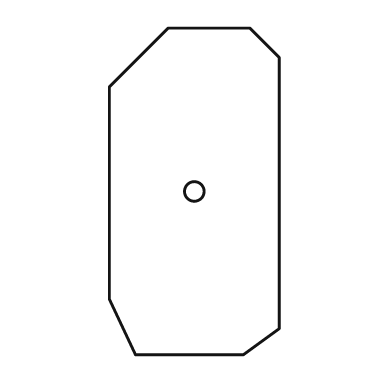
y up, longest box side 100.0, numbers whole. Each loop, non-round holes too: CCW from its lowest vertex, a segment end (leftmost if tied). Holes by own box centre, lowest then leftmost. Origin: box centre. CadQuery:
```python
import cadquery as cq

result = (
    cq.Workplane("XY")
    .moveTo(-18.0, -50.0)
    .lineTo(15.0, -50.0)
    .lineTo(26.0, -42.0)
    .lineTo(26.0, 41.0)
    .lineTo(17.0, 50.0)
    .lineTo(-8.0, 50.0)
    .lineTo(-26.0, 32.0)
    .lineTo(-26.0, -33.0)
    .close()
    .moveTo(0.0, 0.0)
    .circle(3.0)
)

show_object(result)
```